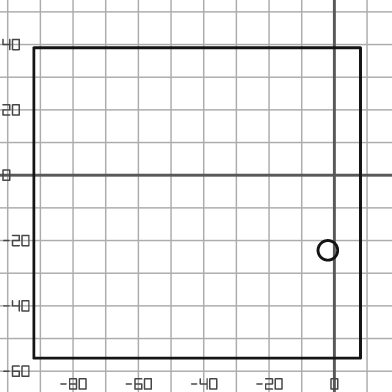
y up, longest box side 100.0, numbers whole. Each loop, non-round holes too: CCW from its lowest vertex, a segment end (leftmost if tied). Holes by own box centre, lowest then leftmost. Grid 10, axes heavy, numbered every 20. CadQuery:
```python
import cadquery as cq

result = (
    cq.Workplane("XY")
    .moveTo(-92.0, -56.0)
    .lineTo(8.0, -56.0)
    .lineTo(8.0, 39.0)
    .lineTo(-92.0, 39.0)
    .close()
    .moveTo(-2.0, -23.0)
    .circle(3.0)
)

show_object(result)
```